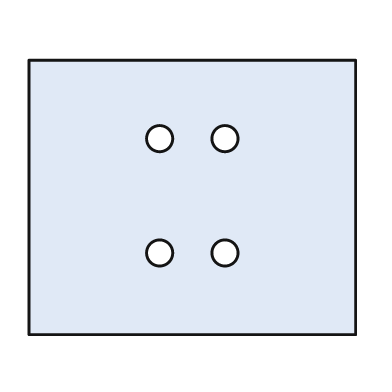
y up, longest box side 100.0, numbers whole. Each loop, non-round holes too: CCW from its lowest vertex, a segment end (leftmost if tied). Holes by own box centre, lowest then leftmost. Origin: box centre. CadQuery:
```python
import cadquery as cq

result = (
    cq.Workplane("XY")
    .moveTo(-50.0, -42.0)
    .lineTo(50.0, -42.0)
    .lineTo(50.0, 42.0)
    .lineTo(-50.0, 42.0)
    .close()
    .moveTo(-10.0, -17.0)
    .circle(4.0)
    .moveTo(10.0, -17.0)
    .circle(4.0)
    .moveTo(-10.0, 18.0)
    .circle(4.0)
    .moveTo(10.0, 18.0)
    .circle(4.0)
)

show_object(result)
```